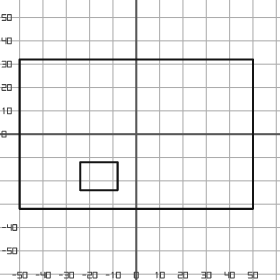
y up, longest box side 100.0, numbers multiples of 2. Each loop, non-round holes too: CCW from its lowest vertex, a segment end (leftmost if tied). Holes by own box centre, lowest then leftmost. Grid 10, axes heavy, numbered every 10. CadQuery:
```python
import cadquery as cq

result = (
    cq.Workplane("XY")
    .moveTo(-50.0, -32.0)
    .lineTo(50.0, -32.0)
    .lineTo(50.0, 32.0)
    .lineTo(-50.0, 32.0)
    .close()
    .moveTo(-24.0, -24.0)
    .lineTo(-8.0, -24.0)
    .lineTo(-8.0, -12.0)
    .lineTo(-24.0, -12.0)
    .close()
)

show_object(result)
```